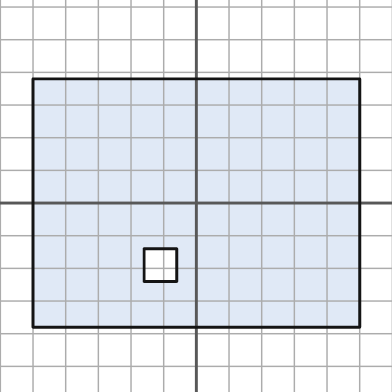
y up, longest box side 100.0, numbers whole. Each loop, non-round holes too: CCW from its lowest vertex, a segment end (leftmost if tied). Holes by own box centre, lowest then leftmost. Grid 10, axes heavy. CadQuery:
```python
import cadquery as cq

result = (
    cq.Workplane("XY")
    .moveTo(-50.0, -38.0)
    .lineTo(50.0, -38.0)
    .lineTo(50.0, 38.0)
    .lineTo(-50.0, 38.0)
    .close()
    .moveTo(-16.0, -24.0)
    .lineTo(-6.0, -24.0)
    .lineTo(-6.0, -14.0)
    .lineTo(-16.0, -14.0)
    .close()
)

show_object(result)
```